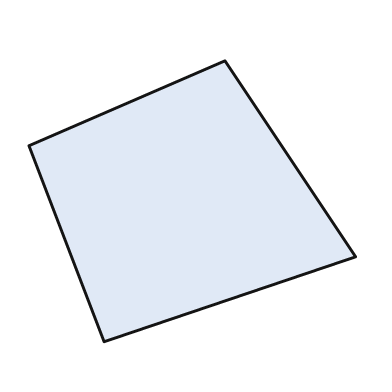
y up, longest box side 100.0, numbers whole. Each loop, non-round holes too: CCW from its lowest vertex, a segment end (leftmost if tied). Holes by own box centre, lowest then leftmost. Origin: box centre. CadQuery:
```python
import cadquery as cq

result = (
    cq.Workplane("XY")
    .moveTo(-27.0, -43.0)
    .lineTo(50.0, -17.0)
    .lineTo(10.0, 43.0)
    .lineTo(-50.0, 17.0)
    .close()
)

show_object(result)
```